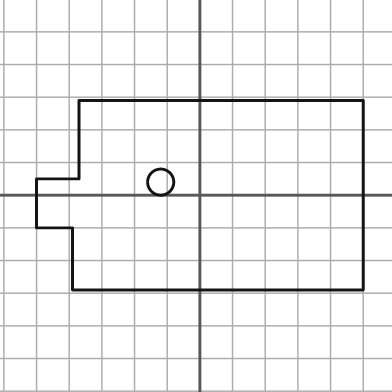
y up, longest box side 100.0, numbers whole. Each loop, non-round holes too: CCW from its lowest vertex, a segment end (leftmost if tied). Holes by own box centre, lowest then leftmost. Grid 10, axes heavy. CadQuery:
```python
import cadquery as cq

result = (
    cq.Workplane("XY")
    .moveTo(-39.0, -29.0)
    .lineTo(50.0, -29.0)
    .lineTo(50.0, 29.0)
    .lineTo(-37.0, 29.0)
    .lineTo(-37.0, 5.0)
    .lineTo(-50.0, 5.0)
    .lineTo(-50.0, -10.0)
    .lineTo(-39.0, -10.0)
    .close()
    .moveTo(-12.0, 4.0)
    .circle(4.0)
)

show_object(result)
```